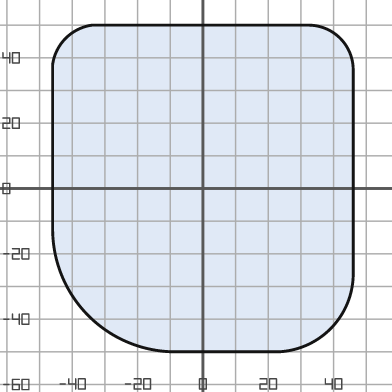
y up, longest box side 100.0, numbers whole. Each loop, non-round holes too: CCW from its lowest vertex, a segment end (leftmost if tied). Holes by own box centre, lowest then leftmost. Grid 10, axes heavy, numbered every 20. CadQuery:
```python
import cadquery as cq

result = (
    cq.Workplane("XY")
    .moveTo(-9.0, -50.0)
    .lineTo(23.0, -50.0)
    .threePointArc((39.0, -43.0), (46.0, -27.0))
    .lineTo(46.0, 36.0)
    .threePointArc((42.0, 46.0), (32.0, 50.0))
    .lineTo(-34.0, 50.0)
    .threePointArc((-42.0, 46.0), (-46.0, 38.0))
    .lineTo(-46.0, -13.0)
    .threePointArc((-35.0, -39.0), (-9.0, -50.0))
    .close()
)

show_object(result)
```